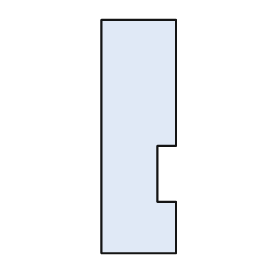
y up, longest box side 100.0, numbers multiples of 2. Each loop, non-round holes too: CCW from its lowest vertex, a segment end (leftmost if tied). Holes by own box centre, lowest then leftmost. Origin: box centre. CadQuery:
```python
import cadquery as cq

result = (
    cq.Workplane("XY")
    .moveTo(-16.0, -50.0)
    .lineTo(16.0, -50.0)
    .lineTo(16.0, -28.0)
    .lineTo(8.0, -28.0)
    .lineTo(8.0, -4.0)
    .lineTo(16.0, -4.0)
    .lineTo(16.0, 50.0)
    .lineTo(-16.0, 50.0)
    .close()
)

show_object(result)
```